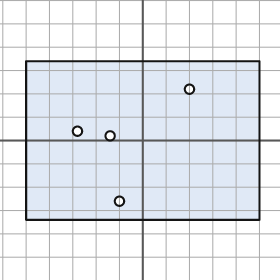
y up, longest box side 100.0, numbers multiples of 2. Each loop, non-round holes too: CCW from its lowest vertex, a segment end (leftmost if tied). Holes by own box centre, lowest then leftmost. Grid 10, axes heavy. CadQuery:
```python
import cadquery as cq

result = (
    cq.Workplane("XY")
    .moveTo(-50.0, -34.0)
    .lineTo(50.0, -34.0)
    .lineTo(50.0, 34.0)
    .lineTo(-50.0, 34.0)
    .close()
    .moveTo(-10.0, -26.0)
    .circle(2.0)
    .moveTo(-14.0, 2.0)
    .circle(2.0)
    .moveTo(-28.0, 4.0)
    .circle(2.0)
    .moveTo(20.0, 22.0)
    .circle(2.0)
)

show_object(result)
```